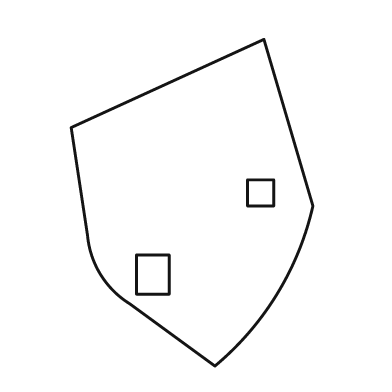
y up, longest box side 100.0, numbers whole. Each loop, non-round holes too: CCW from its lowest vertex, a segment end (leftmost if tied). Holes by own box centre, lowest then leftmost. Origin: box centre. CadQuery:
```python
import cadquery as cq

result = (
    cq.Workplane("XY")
    .moveTo(7.0, -50.0)
    .threePointArc((26.0, -28.0), (37.0, -1.0))
    .lineTo(22.0, 50.0)
    .lineTo(-37.0, 23.0)
    .lineTo(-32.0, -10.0)
    .threePointArc((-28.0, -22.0), (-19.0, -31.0))
    .close()
    .moveTo(-17.0, -28.0)
    .lineTo(-7.0, -28.0)
    .lineTo(-7.0, -16.0)
    .lineTo(-17.0, -16.0)
    .close()
    .moveTo(17.0, -1.0)
    .lineTo(25.0, -1.0)
    .lineTo(25.0, 7.0)
    .lineTo(17.0, 7.0)
    .close()
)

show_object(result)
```